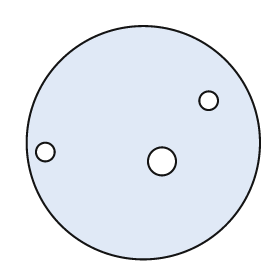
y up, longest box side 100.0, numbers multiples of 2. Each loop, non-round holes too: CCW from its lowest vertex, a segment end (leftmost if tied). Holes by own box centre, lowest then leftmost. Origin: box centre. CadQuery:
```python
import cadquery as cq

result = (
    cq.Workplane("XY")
    .moveTo(0.0, 0.0)
    .circle(50.0)
    .moveTo(8.0, -8.0)
    .circle(6.0)
    .moveTo(-42.0, -4.0)
    .circle(4.0)
    .moveTo(28.0, 18.0)
    .circle(4.0)
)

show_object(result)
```